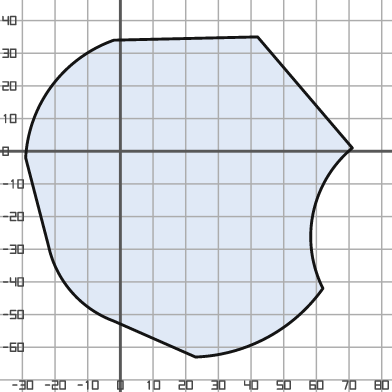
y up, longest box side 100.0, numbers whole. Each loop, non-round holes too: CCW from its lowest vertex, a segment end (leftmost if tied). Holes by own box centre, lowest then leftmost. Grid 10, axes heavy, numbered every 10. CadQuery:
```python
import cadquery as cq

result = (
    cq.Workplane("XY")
    .moveTo(23.0, -63.0)
    .threePointArc((45.0, -57.0), (62.0, -42.0))
    .threePointArc((59.0, -19.0), (71.0, 1.0))
    .lineTo(42.0, 35.0)
    .lineTo(-2.0, 34.0)
    .threePointArc((-21.0, 20.0), (-29.0, -2.0))
    .lineTo(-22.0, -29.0)
    .threePointArc((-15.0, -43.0), (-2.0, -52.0))
    .close()
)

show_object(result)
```